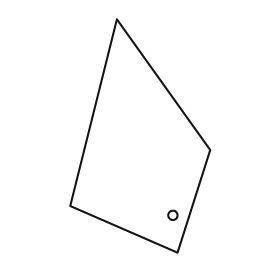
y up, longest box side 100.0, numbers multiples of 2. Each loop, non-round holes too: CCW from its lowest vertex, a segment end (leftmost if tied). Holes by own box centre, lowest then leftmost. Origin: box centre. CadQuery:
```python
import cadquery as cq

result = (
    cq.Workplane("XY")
    .moveTo(16.0, -50.0)
    .lineTo(30.0, -6.0)
    .lineTo(-10.0, 50.0)
    .lineTo(-30.0, -30.0)
    .close()
    .moveTo(14.0, -34.0)
    .circle(2.0)
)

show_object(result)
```